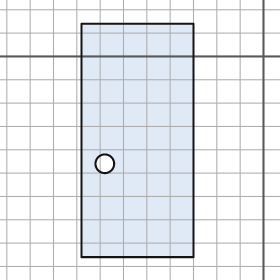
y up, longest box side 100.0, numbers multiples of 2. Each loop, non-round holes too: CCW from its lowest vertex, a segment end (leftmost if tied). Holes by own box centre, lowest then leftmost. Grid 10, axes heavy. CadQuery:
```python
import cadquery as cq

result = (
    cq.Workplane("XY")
    .moveTo(-78.0, -86.0)
    .lineTo(-30.0, -86.0)
    .lineTo(-30.0, 14.0)
    .lineTo(-78.0, 14.0)
    .close()
    .moveTo(-68.0, -46.0)
    .circle(4.0)
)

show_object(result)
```